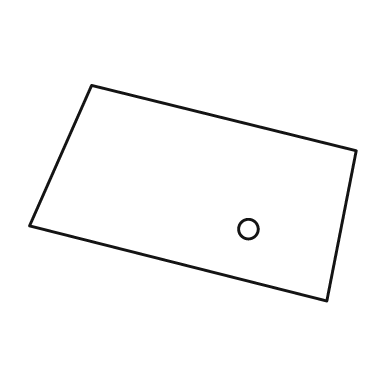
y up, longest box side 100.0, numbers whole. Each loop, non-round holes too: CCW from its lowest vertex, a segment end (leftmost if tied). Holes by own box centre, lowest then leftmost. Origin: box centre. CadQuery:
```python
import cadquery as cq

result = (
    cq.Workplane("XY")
    .moveTo(41.0, -33.0)
    .lineTo(50.0, 13.0)
    .lineTo(-31.0, 33.0)
    .lineTo(-50.0, -10.0)
    .close()
    .moveTo(17.0, -11.0)
    .circle(3.0)
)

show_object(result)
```